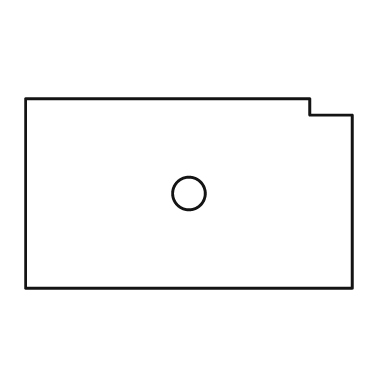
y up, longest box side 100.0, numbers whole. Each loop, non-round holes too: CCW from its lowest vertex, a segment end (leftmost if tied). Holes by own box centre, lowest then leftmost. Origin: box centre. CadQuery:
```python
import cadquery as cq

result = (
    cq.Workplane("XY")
    .moveTo(-50.0, -29.0)
    .lineTo(50.0, -29.0)
    .lineTo(50.0, 24.0)
    .lineTo(37.0, 24.0)
    .lineTo(37.0, 29.0)
    .lineTo(-50.0, 29.0)
    .close()
    .moveTo(0.0, 0.0)
    .circle(5.0)
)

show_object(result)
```